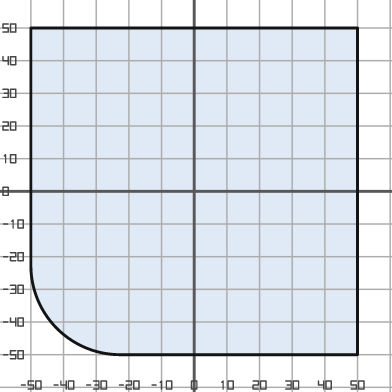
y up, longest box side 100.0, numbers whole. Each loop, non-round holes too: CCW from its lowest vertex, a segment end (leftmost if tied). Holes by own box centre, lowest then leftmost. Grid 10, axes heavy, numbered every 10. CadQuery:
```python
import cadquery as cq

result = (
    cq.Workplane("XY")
    .moveTo(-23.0, -50.0)
    .lineTo(50.0, -50.0)
    .lineTo(50.0, 50.0)
    .lineTo(-50.0, 50.0)
    .lineTo(-50.0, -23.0)
    .threePointArc((-42.0, -42.0), (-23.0, -50.0))
    .close()
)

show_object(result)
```